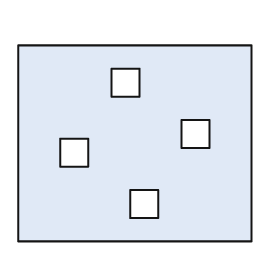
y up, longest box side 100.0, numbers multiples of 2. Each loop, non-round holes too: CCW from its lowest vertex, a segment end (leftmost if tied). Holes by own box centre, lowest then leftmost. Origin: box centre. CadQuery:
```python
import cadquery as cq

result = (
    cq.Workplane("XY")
    .moveTo(-50.0, -42.0)
    .lineTo(50.0, -42.0)
    .lineTo(50.0, 42.0)
    .lineTo(-50.0, 42.0)
    .close()
    .moveTo(-2.0, -32.0)
    .lineTo(10.0, -32.0)
    .lineTo(10.0, -20.0)
    .lineTo(-2.0, -20.0)
    .close()
    .moveTo(-32.0, -10.0)
    .lineTo(-20.0, -10.0)
    .lineTo(-20.0, 2.0)
    .lineTo(-32.0, 2.0)
    .close()
    .moveTo(20.0, -2.0)
    .lineTo(32.0, -2.0)
    .lineTo(32.0, 10.0)
    .lineTo(20.0, 10.0)
    .close()
    .moveTo(-10.0, 20.0)
    .lineTo(2.0, 20.0)
    .lineTo(2.0, 32.0)
    .lineTo(-10.0, 32.0)
    .close()
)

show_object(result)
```